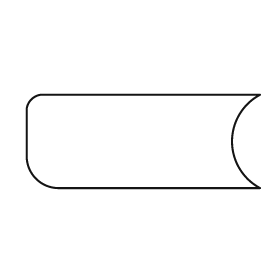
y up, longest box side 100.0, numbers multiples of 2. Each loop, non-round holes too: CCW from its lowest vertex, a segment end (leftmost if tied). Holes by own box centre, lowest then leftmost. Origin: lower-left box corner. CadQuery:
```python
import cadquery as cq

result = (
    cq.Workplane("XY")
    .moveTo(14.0, 0.0)
    .lineTo(100.0, 0.0)
    .threePointArc((88.0, 20.0), (100.0, 40.0))
    .lineTo(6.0, 40.0)
    .threePointArc((2.0, 38.0), (0.0, 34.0))
    .lineTo(0.0, 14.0)
    .threePointArc((4.0, 4.0), (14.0, 0.0))
    .close()
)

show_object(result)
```